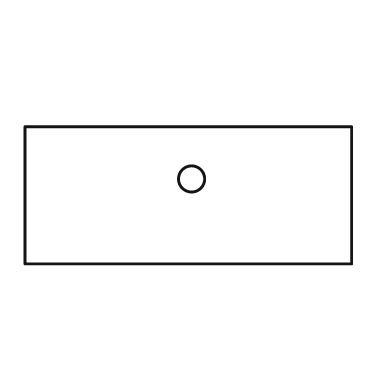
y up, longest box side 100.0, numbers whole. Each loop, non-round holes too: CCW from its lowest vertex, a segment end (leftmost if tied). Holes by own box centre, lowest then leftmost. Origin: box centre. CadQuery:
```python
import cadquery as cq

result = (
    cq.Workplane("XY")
    .moveTo(-50.0, -21.0)
    .lineTo(50.0, -21.0)
    .lineTo(50.0, 21.0)
    .lineTo(-50.0, 21.0)
    .close()
    .moveTo(1.0, 5.0)
    .circle(4.0)
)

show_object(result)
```